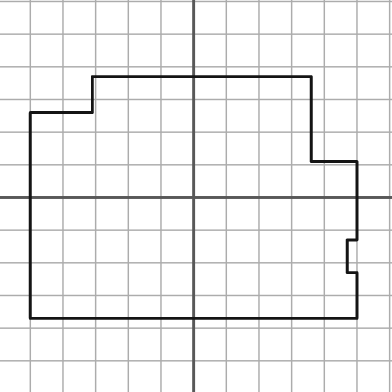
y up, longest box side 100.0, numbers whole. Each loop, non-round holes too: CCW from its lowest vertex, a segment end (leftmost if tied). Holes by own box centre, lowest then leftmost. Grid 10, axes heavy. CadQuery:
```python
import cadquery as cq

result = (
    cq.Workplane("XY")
    .moveTo(-50.0, -37.0)
    .lineTo(50.0, -37.0)
    .lineTo(50.0, -23.0)
    .lineTo(47.0, -23.0)
    .lineTo(47.0, -13.0)
    .lineTo(50.0, -13.0)
    .lineTo(50.0, 11.0)
    .lineTo(36.0, 11.0)
    .lineTo(36.0, 37.0)
    .lineTo(-31.0, 37.0)
    .lineTo(-31.0, 26.0)
    .lineTo(-50.0, 26.0)
    .close()
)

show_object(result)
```